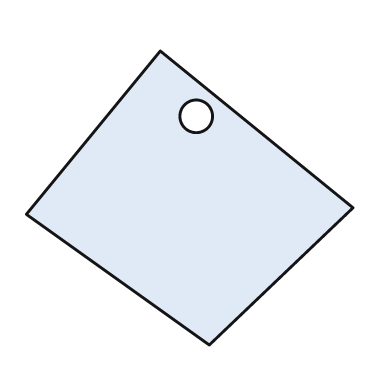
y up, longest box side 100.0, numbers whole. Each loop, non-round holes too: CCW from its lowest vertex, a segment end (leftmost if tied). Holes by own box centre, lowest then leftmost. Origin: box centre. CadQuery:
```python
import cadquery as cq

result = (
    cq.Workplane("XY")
    .moveTo(6.0, -45.0)
    .lineTo(50.0, -3.0)
    .lineTo(-9.0, 45.0)
    .lineTo(-50.0, -5.0)
    .close()
    .moveTo(2.0, 25.0)
    .circle(5.0)
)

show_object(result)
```